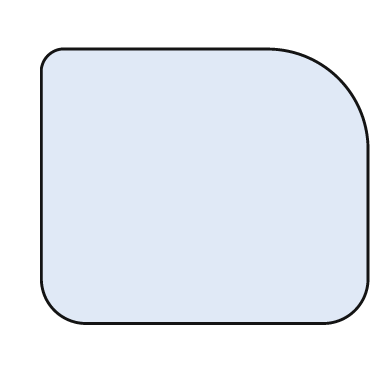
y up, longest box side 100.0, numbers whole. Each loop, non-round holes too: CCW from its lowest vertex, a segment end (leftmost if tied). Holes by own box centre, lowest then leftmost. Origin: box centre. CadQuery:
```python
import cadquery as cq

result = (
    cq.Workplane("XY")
    .moveTo(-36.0, -42.0)
    .lineTo(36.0, -42.0)
    .threePointArc((46.0, -38.0), (50.0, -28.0))
    .lineTo(50.0, 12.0)
    .threePointArc((41.0, 33.0), (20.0, 42.0))
    .lineTo(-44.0, 42.0)
    .threePointArc((-48.0, 40.0), (-50.0, 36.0))
    .lineTo(-50.0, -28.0)
    .threePointArc((-46.0, -38.0), (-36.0, -42.0))
    .close()
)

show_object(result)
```